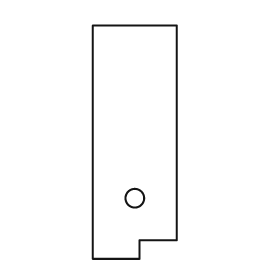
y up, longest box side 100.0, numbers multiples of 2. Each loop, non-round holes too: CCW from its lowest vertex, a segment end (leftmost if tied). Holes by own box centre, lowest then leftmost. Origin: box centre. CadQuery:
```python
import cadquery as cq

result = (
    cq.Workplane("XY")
    .moveTo(-18.0, -50.0)
    .lineTo(2.0, -50.0)
    .lineTo(2.0, -42.0)
    .lineTo(18.0, -42.0)
    .lineTo(18.0, 50.0)
    .lineTo(-18.0, 50.0)
    .close()
    .moveTo(0.0, -24.0)
    .circle(4.0)
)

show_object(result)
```